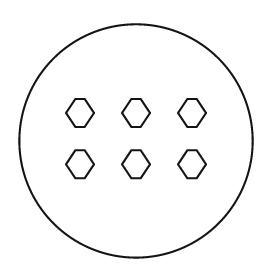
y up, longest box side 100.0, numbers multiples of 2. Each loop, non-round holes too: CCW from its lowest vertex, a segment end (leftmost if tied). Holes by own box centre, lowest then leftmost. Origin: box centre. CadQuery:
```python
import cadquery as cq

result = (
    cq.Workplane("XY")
    .moveTo(0.0, 0.0)
    .circle(50.0)
    .moveTo(-26.0, -16.0)
    .lineTo(-22.0, -16.0)
    .lineTo(-18.0, -10.0)
    .lineTo(-22.0, -4.0)
    .lineTo(-26.0, -4.0)
    .lineTo(-30.0, -10.0)
    .close()
    .moveTo(-2.0, -16.0)
    .lineTo(2.0, -16.0)
    .lineTo(6.0, -10.0)
    .lineTo(2.0, -4.0)
    .lineTo(-2.0, -4.0)
    .lineTo(-6.0, -10.0)
    .close()
    .moveTo(22.0, -16.0)
    .lineTo(26.0, -16.0)
    .lineTo(30.0, -10.0)
    .lineTo(26.0, -4.0)
    .lineTo(22.0, -4.0)
    .lineTo(18.0, -10.0)
    .close()
    .moveTo(-26.0, 6.0)
    .lineTo(-22.0, 6.0)
    .lineTo(-18.0, 12.0)
    .lineTo(-22.0, 18.0)
    .lineTo(-26.0, 18.0)
    .lineTo(-30.0, 12.0)
    .close()
    .moveTo(-2.0, 6.0)
    .lineTo(2.0, 6.0)
    .lineTo(6.0, 12.0)
    .lineTo(2.0, 18.0)
    .lineTo(-2.0, 18.0)
    .lineTo(-6.0, 12.0)
    .close()
    .moveTo(22.0, 6.0)
    .lineTo(26.0, 6.0)
    .lineTo(30.0, 12.0)
    .lineTo(26.0, 18.0)
    .lineTo(22.0, 18.0)
    .lineTo(18.0, 12.0)
    .close()
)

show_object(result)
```